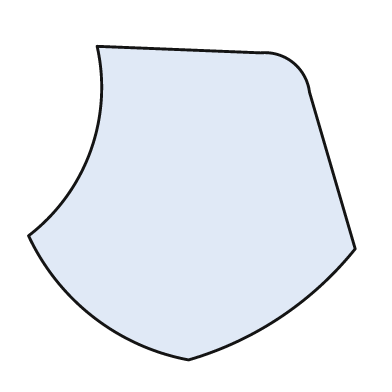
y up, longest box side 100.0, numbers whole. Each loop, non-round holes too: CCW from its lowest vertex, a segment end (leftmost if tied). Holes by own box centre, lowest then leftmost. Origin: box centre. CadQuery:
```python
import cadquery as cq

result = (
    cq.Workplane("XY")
    .moveTo(-1.0, -48.0)
    .threePointArc((27.0, -35.0), (50.0, -14.0))
    .lineTo(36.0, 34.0)
    .threePointArc((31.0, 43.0), (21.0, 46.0))
    .lineTo(-29.0, 48.0)
    .threePointArc((-31.0, 16.0), (-50.0, -10.0))
    .threePointArc((-30.0, -35.0), (-1.0, -48.0))
    .close()
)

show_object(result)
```